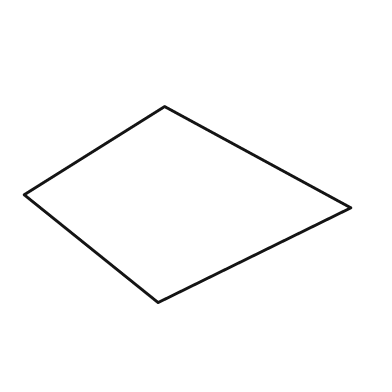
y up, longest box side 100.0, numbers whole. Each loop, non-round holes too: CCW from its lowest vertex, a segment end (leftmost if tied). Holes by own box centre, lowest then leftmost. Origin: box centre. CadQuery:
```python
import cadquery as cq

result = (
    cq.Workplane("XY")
    .moveTo(-9.0, -30.0)
    .lineTo(50.0, -1.0)
    .lineTo(-7.0, 30.0)
    .lineTo(-50.0, 3.0)
    .close()
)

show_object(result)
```